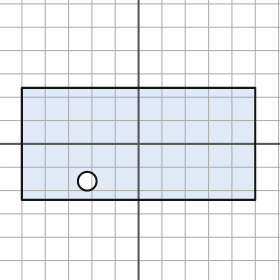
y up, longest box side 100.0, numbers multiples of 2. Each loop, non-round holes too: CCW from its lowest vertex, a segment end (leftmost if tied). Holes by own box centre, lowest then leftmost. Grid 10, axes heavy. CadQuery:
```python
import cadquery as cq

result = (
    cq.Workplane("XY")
    .moveTo(-50.0, -24.0)
    .lineTo(50.0, -24.0)
    .lineTo(50.0, 24.0)
    .lineTo(-50.0, 24.0)
    .close()
    .moveTo(-22.0, -16.0)
    .circle(4.0)
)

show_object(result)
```